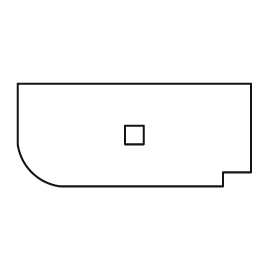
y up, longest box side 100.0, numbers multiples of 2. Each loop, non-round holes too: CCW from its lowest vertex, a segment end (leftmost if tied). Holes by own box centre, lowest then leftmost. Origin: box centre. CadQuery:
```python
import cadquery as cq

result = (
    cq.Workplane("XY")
    .moveTo(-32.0, -22.0)
    .lineTo(38.0, -22.0)
    .lineTo(38.0, -16.0)
    .lineTo(50.0, -16.0)
    .lineTo(50.0, 22.0)
    .lineTo(-50.0, 22.0)
    .lineTo(-50.0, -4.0)
    .threePointArc((-44.0, -16.0), (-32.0, -22.0))
    .close()
    .moveTo(-4.0, -4.0)
    .lineTo(4.0, -4.0)
    .lineTo(4.0, 4.0)
    .lineTo(-4.0, 4.0)
    .close()
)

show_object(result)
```